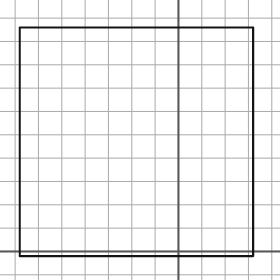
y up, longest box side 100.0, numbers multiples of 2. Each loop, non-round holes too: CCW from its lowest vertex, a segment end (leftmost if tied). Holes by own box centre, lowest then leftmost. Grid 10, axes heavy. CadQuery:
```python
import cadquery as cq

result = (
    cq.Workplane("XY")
    .moveTo(-68.0, -2.0)
    .lineTo(32.0, -2.0)
    .lineTo(32.0, 96.0)
    .lineTo(-68.0, 96.0)
    .close()
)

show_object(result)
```